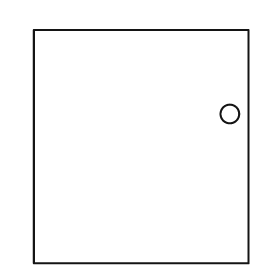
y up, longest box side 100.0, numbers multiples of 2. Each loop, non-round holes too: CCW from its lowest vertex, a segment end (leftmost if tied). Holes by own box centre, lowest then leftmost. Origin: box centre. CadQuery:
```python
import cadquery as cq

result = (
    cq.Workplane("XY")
    .moveTo(-46.0, -50.0)
    .lineTo(46.0, -50.0)
    .lineTo(46.0, 50.0)
    .lineTo(-46.0, 50.0)
    .close()
    .moveTo(38.0, 14.0)
    .circle(4.0)
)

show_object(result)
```